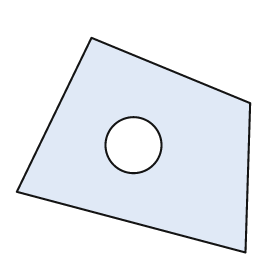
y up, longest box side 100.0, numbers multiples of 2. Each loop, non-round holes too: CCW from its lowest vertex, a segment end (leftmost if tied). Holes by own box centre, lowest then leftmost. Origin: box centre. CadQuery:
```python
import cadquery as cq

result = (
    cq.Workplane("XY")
    .moveTo(48.0, -46.0)
    .lineTo(50.0, 18.0)
    .lineTo(-18.0, 46.0)
    .lineTo(-50.0, -20.0)
    .close()
    .moveTo(0.0, 0.0)
    .circle(12.0)
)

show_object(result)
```